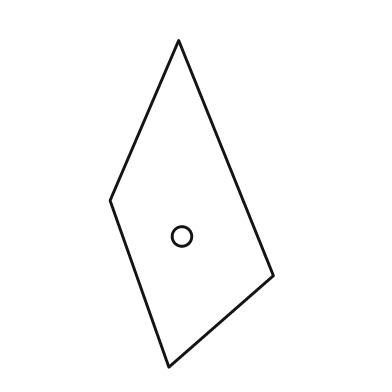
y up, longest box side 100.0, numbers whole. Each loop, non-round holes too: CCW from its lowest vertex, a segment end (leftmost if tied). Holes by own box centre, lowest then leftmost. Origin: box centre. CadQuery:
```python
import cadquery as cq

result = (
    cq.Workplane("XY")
    .moveTo(-7.0, -50.0)
    .lineTo(25.0, -22.0)
    .lineTo(-4.0, 50.0)
    .lineTo(-25.0, 1.0)
    .close()
    .moveTo(-3.0, -10.0)
    .circle(3.0)
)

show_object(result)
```